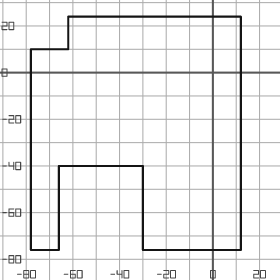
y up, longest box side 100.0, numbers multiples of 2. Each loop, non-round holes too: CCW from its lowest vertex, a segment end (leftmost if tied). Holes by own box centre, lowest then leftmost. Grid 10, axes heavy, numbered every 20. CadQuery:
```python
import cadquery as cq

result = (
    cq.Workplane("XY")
    .moveTo(-78.0, -76.0)
    .lineTo(-66.0, -76.0)
    .lineTo(-66.0, -40.0)
    .lineTo(-30.0, -40.0)
    .lineTo(-30.0, -76.0)
    .lineTo(12.0, -76.0)
    .lineTo(12.0, 24.0)
    .lineTo(-62.0, 24.0)
    .lineTo(-62.0, 10.0)
    .lineTo(-78.0, 10.0)
    .close()
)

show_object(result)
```